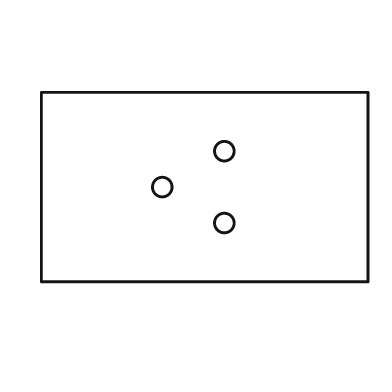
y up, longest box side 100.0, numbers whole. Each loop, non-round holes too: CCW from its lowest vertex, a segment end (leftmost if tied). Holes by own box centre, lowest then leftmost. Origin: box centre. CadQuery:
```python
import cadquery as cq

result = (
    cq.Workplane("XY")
    .moveTo(-50.0, -29.0)
    .lineTo(50.0, -29.0)
    .lineTo(50.0, 29.0)
    .lineTo(-50.0, 29.0)
    .close()
    .moveTo(6.0, -11.0)
    .circle(3.0)
    .moveTo(-13.0, 0.0)
    .circle(3.0)
    .moveTo(6.0, 11.0)
    .circle(3.0)
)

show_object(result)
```